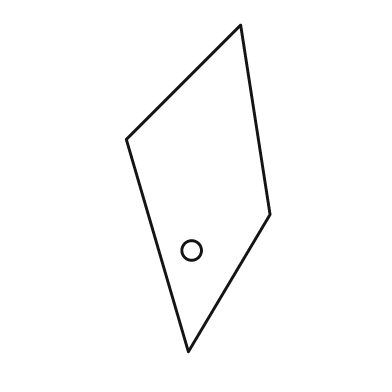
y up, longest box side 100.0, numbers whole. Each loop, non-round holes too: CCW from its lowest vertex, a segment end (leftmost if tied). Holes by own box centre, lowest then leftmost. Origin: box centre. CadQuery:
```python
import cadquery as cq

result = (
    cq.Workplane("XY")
    .moveTo(-3.0, -50.0)
    .lineTo(22.0, -8.0)
    .lineTo(13.0, 50.0)
    .lineTo(-22.0, 15.0)
    .close()
    .moveTo(-2.0, -19.0)
    .circle(3.0)
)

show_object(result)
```